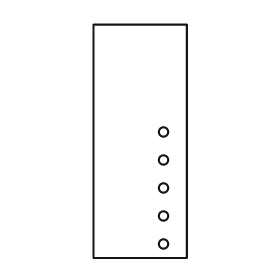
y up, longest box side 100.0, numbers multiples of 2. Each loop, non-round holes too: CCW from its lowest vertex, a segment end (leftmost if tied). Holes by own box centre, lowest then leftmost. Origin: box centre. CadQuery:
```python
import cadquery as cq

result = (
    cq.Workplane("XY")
    .moveTo(-20.0, -50.0)
    .lineTo(20.0, -50.0)
    .lineTo(20.0, 50.0)
    .lineTo(-20.0, 50.0)
    .close()
    .moveTo(10.0, -44.0)
    .circle(2.0)
    .moveTo(10.0, -32.0)
    .circle(2.0)
    .moveTo(10.0, -20.0)
    .circle(2.0)
    .moveTo(10.0, -8.0)
    .circle(2.0)
    .moveTo(10.0, 4.0)
    .circle(2.0)
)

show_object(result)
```